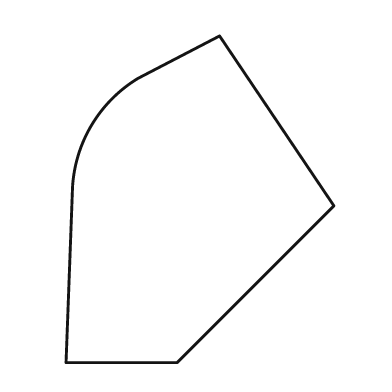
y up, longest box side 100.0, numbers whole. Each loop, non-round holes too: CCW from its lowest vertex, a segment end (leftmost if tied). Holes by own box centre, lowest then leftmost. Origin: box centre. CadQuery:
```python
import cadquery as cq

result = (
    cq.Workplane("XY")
    .moveTo(-41.0, -50.0)
    .lineTo(-7.0, -50.0)
    .lineTo(41.0, -2.0)
    .lineTo(6.0, 50.0)
    .lineTo(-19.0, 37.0)
    .threePointArc((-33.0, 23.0), (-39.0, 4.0))
    .close()
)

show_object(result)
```